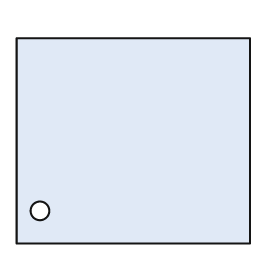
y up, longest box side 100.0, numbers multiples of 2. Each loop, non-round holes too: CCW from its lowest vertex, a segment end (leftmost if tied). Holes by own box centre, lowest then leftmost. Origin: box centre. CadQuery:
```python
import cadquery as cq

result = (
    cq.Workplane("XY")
    .moveTo(-50.0, -44.0)
    .lineTo(50.0, -44.0)
    .lineTo(50.0, 44.0)
    .lineTo(-50.0, 44.0)
    .close()
    .moveTo(-40.0, -30.0)
    .circle(4.0)
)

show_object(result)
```